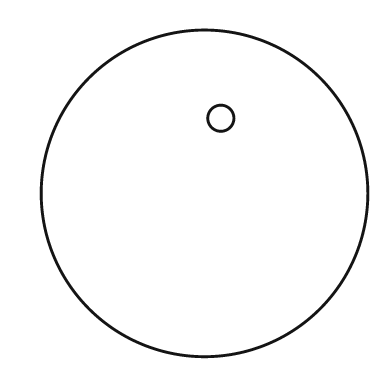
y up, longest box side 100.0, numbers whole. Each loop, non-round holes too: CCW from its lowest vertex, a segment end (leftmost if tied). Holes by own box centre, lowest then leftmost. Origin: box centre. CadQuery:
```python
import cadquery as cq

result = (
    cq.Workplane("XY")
    .moveTo(0.0, 0.0)
    .circle(50.0)
    .moveTo(5.0, 23.0)
    .circle(4.0)
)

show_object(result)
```